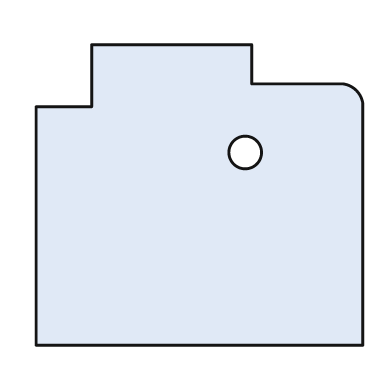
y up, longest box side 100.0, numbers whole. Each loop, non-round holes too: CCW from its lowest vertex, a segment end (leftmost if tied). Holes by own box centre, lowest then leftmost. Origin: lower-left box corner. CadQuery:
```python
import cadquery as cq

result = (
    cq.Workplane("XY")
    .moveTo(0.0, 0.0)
    .lineTo(100.0, 0.0)
    .lineTo(100.0, 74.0)
    .threePointArc((98.0, 78.0), (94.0, 80.0))
    .lineTo(66.0, 80.0)
    .lineTo(66.0, 92.0)
    .lineTo(17.0, 92.0)
    .lineTo(17.0, 73.0)
    .lineTo(0.0, 73.0)
    .close()
    .moveTo(64.0, 59.0)
    .circle(5.0)
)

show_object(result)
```